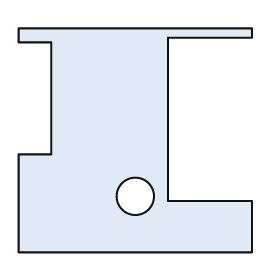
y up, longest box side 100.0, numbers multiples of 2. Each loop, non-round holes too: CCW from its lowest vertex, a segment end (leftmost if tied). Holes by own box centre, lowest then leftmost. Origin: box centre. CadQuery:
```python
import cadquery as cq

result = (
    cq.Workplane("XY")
    .moveTo(-50.0, -48.0)
    .lineTo(50.0, -48.0)
    .lineTo(50.0, -26.0)
    .lineTo(14.0, -26.0)
    .lineTo(14.0, 44.0)
    .lineTo(50.0, 44.0)
    .lineTo(50.0, 48.0)
    .lineTo(-50.0, 48.0)
    .lineTo(-50.0, 42.0)
    .lineTo(-36.0, 42.0)
    .lineTo(-36.0, -6.0)
    .lineTo(-50.0, -6.0)
    .close()
    .moveTo(0.0, -24.0)
    .circle(8.0)
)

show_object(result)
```